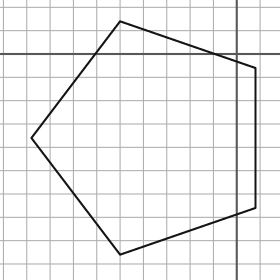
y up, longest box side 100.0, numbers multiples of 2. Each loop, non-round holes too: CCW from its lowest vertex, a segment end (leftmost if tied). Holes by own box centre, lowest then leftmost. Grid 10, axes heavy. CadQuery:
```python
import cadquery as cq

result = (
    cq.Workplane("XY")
    .moveTo(-50.0, -86.0)
    .lineTo(8.0, -66.0)
    .lineTo(8.0, -6.0)
    .lineTo(-50.0, 14.0)
    .lineTo(-88.0, -36.0)
    .close()
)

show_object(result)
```